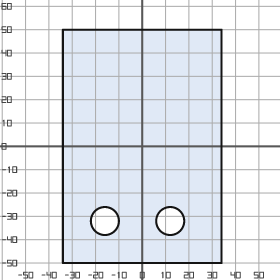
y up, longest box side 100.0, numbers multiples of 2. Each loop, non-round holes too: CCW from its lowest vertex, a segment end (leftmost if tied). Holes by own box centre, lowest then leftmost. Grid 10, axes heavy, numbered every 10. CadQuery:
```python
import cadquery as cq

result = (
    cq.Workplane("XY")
    .moveTo(-34.0, -50.0)
    .lineTo(34.0, -50.0)
    .lineTo(34.0, 50.0)
    .lineTo(-34.0, 50.0)
    .close()
    .moveTo(-16.0, -32.0)
    .circle(6.0)
    .moveTo(12.0, -32.0)
    .circle(6.0)
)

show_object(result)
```